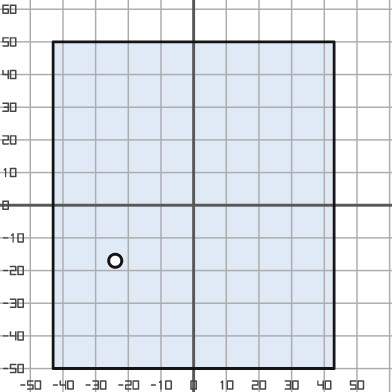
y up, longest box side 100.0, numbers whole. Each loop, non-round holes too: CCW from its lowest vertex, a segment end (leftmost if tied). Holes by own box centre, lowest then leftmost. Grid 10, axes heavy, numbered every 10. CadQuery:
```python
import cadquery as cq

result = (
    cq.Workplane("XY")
    .moveTo(-43.0, -50.0)
    .lineTo(43.0, -50.0)
    .lineTo(43.0, 50.0)
    .lineTo(-43.0, 50.0)
    .close()
    .moveTo(-24.0, -17.0)
    .circle(2.0)
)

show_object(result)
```